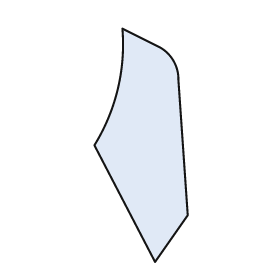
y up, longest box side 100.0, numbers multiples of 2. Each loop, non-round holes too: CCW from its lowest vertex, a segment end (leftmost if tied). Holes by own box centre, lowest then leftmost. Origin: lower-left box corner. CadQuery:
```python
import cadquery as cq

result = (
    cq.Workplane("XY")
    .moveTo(26.0, 0.0)
    .lineTo(40.0, 20.0)
    .lineTo(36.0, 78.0)
    .threePointArc((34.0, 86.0), (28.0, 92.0))
    .lineTo(12.0, 100.0)
    .threePointArc((10.0, 74.0), (0.0, 50.0))
    .close()
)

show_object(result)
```